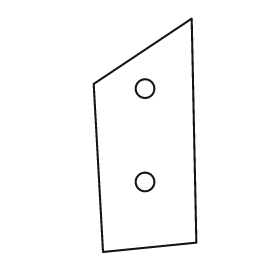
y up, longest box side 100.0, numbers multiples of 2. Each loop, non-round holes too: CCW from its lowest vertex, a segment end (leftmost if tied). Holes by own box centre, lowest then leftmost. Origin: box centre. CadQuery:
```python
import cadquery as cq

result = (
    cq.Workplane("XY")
    .moveTo(-18.0, -50.0)
    .lineTo(22.0, -46.0)
    .lineTo(20.0, 50.0)
    .lineTo(-22.0, 22.0)
    .close()
    .moveTo(0.0, -20.0)
    .circle(4.0)
    .moveTo(0.0, 20.0)
    .circle(4.0)
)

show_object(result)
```